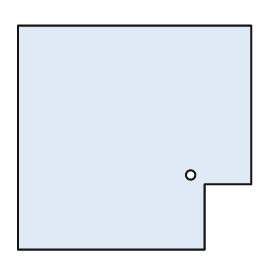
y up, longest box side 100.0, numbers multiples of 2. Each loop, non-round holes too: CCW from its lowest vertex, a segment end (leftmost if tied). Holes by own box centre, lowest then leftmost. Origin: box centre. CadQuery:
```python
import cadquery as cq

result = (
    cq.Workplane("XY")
    .moveTo(-50.0, -48.0)
    .lineTo(30.0, -48.0)
    .lineTo(30.0, -20.0)
    .lineTo(50.0, -20.0)
    .lineTo(50.0, 48.0)
    .lineTo(-50.0, 48.0)
    .close()
    .moveTo(24.0, -16.0)
    .circle(2.0)
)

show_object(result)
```